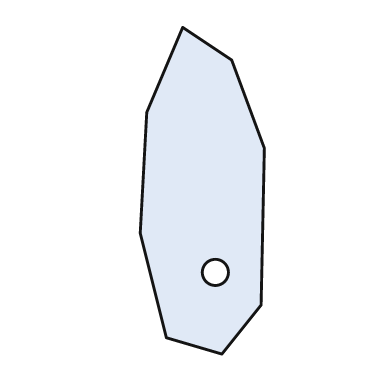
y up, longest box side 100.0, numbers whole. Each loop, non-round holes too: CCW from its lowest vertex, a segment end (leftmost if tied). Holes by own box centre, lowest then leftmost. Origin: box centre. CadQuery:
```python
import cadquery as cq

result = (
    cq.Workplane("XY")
    .moveTo(6.0, -50.0)
    .lineTo(18.0, -35.0)
    .lineTo(19.0, 13.0)
    .lineTo(9.0, 40.0)
    .lineTo(-6.0, 50.0)
    .lineTo(-17.0, 24.0)
    .lineTo(-19.0, -13.0)
    .lineTo(-11.0, -45.0)
    .close()
    .moveTo(4.0, -25.0)
    .circle(4.0)
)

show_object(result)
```